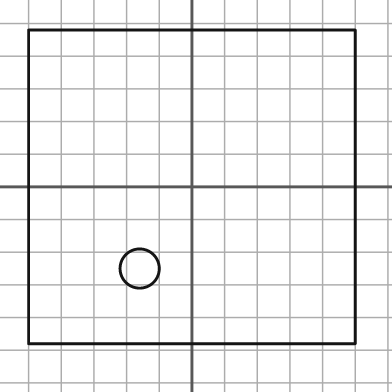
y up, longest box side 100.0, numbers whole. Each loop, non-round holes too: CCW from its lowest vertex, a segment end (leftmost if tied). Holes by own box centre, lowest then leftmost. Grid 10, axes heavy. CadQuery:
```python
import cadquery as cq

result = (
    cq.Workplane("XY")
    .moveTo(-50.0, -48.0)
    .lineTo(50.0, -48.0)
    .lineTo(50.0, 48.0)
    .lineTo(-50.0, 48.0)
    .close()
    .moveTo(-16.0, -25.0)
    .circle(6.0)
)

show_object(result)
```